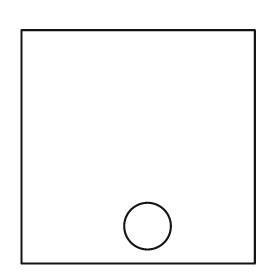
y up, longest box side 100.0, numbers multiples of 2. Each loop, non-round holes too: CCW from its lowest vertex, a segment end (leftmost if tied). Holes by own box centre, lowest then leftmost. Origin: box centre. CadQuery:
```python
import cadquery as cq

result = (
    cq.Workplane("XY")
    .moveTo(-50.0, -50.0)
    .lineTo(50.0, -50.0)
    .lineTo(50.0, 50.0)
    .lineTo(-50.0, 50.0)
    .close()
    .moveTo(4.0, -34.0)
    .circle(10.0)
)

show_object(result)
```